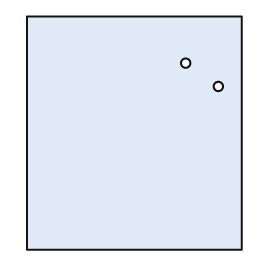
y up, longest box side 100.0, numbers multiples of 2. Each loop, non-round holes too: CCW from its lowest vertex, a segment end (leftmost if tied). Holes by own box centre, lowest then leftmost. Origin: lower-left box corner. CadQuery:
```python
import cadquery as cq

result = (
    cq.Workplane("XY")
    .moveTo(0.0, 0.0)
    .lineTo(92.0, 0.0)
    .lineTo(92.0, 100.0)
    .lineTo(0.0, 100.0)
    .close()
    .moveTo(82.0, 70.0)
    .circle(2.0)
    .moveTo(68.0, 80.0)
    .circle(2.0)
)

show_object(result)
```